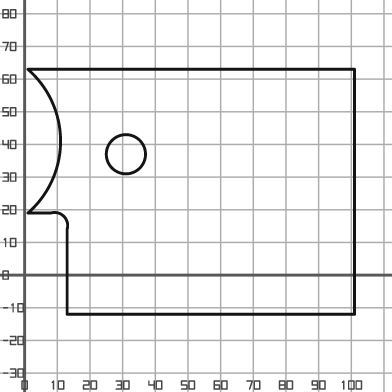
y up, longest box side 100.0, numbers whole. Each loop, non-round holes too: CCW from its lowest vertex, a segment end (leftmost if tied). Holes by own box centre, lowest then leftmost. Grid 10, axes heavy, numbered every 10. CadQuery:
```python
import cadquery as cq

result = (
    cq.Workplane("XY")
    .moveTo(13.0, -12.0)
    .lineTo(101.0, -12.0)
    .lineTo(101.0, 63.0)
    .lineTo(1.0, 63.0)
    .threePointArc((11.0, 41.0), (1.0, 19.0))
    .lineTo(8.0, 19.0)
    .threePointArc((12.0, 18.0), (13.0, 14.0))
    .close()
    .moveTo(31.0, 37.0)
    .circle(6.0)
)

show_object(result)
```